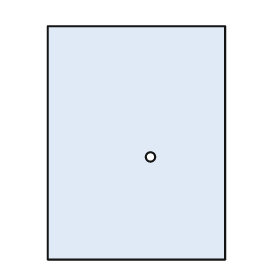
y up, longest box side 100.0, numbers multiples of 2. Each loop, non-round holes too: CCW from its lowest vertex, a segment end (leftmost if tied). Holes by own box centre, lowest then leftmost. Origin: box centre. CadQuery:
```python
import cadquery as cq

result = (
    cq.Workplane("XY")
    .moveTo(-38.0, -50.0)
    .lineTo(38.0, -50.0)
    .lineTo(38.0, 50.0)
    .lineTo(-38.0, 50.0)
    .close()
    .moveTo(6.0, -6.0)
    .circle(2.0)
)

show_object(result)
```